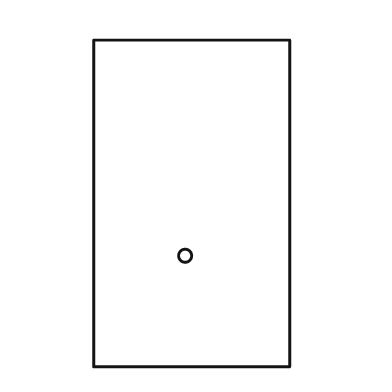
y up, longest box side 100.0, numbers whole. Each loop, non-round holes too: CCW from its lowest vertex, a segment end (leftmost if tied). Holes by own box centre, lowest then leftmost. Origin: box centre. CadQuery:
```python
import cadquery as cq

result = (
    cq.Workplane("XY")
    .moveTo(-30.0, -50.0)
    .lineTo(30.0, -50.0)
    .lineTo(30.0, 50.0)
    .lineTo(-30.0, 50.0)
    .close()
    .moveTo(-2.0, -16.0)
    .circle(2.0)
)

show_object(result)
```